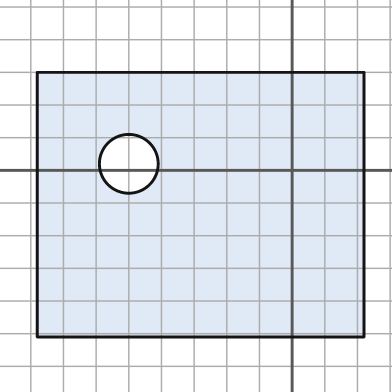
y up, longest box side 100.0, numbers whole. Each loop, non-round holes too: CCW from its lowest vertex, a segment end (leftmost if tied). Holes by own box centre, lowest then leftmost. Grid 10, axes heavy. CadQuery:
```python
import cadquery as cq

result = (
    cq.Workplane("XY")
    .moveTo(-78.0, -51.0)
    .lineTo(22.0, -51.0)
    .lineTo(22.0, 30.0)
    .lineTo(-78.0, 30.0)
    .close()
    .moveTo(-50.0, 2.0)
    .circle(9.0)
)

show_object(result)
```